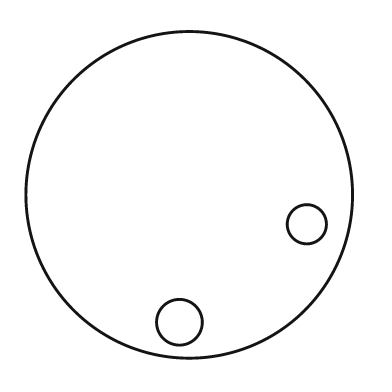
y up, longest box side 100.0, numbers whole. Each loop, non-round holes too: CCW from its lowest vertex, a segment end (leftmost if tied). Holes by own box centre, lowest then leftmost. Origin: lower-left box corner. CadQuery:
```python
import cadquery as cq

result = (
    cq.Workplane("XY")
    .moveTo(50.0, 50.0)
    .circle(50.0)
    .moveTo(47.0, 11.0)
    .circle(7.0)
    .moveTo(86.0, 41.0)
    .circle(6.0)
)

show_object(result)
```